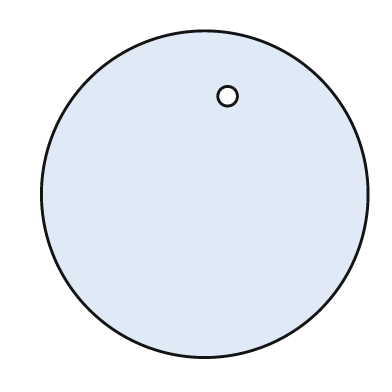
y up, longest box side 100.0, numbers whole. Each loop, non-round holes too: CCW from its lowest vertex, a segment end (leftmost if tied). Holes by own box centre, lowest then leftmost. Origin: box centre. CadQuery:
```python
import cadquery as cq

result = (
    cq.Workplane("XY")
    .moveTo(0.0, 0.0)
    .circle(50.0)
    .moveTo(7.0, 30.0)
    .circle(3.0)
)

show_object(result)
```